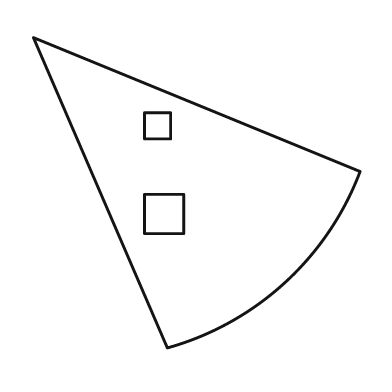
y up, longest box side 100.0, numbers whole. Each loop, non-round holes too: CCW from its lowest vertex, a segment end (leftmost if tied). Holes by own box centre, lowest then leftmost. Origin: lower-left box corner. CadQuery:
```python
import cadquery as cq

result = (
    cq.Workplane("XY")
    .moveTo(41.0, 0.0)
    .threePointArc((77.0, 20.0), (100.0, 54.0))
    .lineTo(0.0, 95.0)
    .close()
    .moveTo(34.0, 35.0)
    .lineTo(46.0, 35.0)
    .lineTo(46.0, 47.0)
    .lineTo(34.0, 47.0)
    .close()
    .moveTo(34.0, 64.0)
    .lineTo(42.0, 64.0)
    .lineTo(42.0, 72.0)
    .lineTo(34.0, 72.0)
    .close()
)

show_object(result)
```